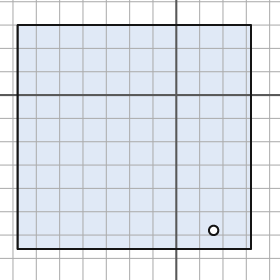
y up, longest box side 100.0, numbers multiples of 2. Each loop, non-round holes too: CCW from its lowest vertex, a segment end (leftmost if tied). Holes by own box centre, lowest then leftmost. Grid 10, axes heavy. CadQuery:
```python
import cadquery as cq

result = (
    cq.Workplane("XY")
    .moveTo(-68.0, -66.0)
    .lineTo(32.0, -66.0)
    .lineTo(32.0, 30.0)
    .lineTo(-68.0, 30.0)
    .close()
    .moveTo(16.0, -58.0)
    .circle(2.0)
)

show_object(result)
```